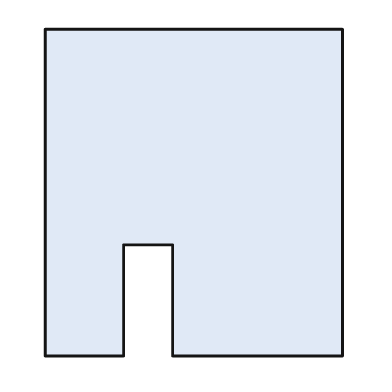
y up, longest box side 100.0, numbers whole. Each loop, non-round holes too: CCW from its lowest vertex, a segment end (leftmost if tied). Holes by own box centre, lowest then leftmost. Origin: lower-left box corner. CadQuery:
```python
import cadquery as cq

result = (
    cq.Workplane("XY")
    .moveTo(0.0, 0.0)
    .lineTo(24.0, 0.0)
    .lineTo(24.0, 34.0)
    .lineTo(39.0, 34.0)
    .lineTo(39.0, 0.0)
    .lineTo(91.0, 0.0)
    .lineTo(91.0, 100.0)
    .lineTo(0.0, 100.0)
    .close()
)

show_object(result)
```